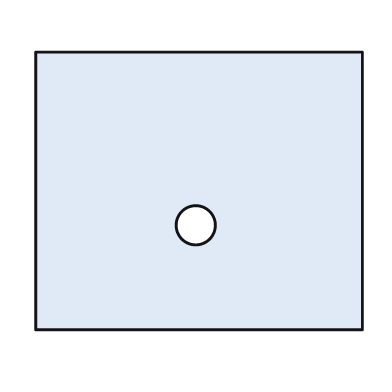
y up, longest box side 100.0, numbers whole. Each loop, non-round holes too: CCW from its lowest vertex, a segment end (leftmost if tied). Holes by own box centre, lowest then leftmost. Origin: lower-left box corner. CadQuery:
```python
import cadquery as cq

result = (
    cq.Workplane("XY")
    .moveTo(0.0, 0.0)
    .lineTo(100.0, 0.0)
    .lineTo(100.0, 85.0)
    .lineTo(0.0, 85.0)
    .close()
    .moveTo(49.0, 32.0)
    .circle(6.0)
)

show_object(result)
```